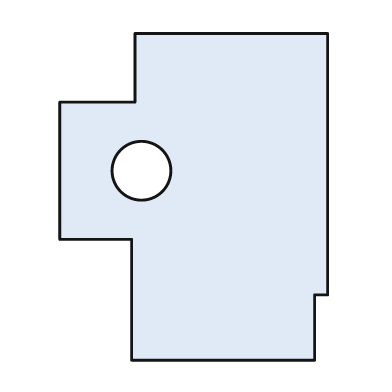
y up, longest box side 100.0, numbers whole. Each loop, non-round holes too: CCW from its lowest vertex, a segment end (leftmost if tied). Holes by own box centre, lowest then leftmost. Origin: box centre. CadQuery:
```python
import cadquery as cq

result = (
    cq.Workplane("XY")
    .moveTo(-19.0, -50.0)
    .lineTo(37.0, -50.0)
    .lineTo(37.0, -30.0)
    .lineTo(41.0, -30.0)
    .lineTo(41.0, 50.0)
    .lineTo(-18.0, 50.0)
    .lineTo(-18.0, 29.0)
    .lineTo(-41.0, 29.0)
    .lineTo(-41.0, -13.0)
    .lineTo(-19.0, -13.0)
    .close()
    .moveTo(-16.0, 8.0)
    .circle(9.0)
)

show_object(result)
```